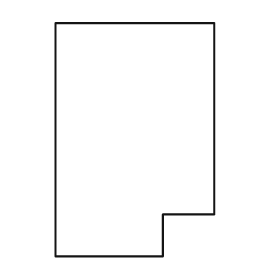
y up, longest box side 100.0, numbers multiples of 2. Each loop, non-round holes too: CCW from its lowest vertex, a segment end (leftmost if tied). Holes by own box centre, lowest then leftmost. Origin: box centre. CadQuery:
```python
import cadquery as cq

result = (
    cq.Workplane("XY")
    .moveTo(-34.0, -50.0)
    .lineTo(12.0, -50.0)
    .lineTo(12.0, -32.0)
    .lineTo(34.0, -32.0)
    .lineTo(34.0, 50.0)
    .lineTo(-34.0, 50.0)
    .close()
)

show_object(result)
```